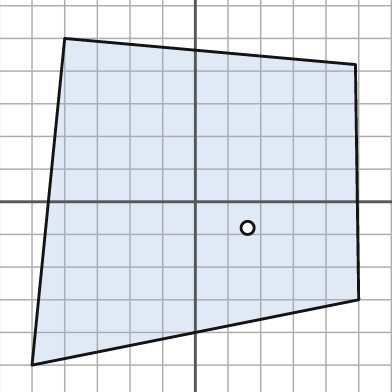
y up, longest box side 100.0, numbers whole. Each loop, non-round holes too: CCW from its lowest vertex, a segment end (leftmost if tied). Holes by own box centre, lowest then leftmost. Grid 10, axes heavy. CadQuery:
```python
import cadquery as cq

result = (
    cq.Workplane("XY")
    .moveTo(-50.0, -50.0)
    .lineTo(50.0, -30.0)
    .lineTo(49.0, 42.0)
    .lineTo(-40.0, 50.0)
    .close()
    .moveTo(16.0, -8.0)
    .circle(2.0)
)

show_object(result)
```